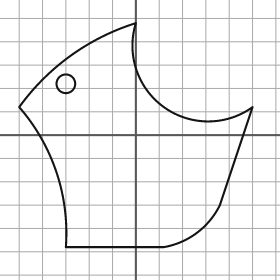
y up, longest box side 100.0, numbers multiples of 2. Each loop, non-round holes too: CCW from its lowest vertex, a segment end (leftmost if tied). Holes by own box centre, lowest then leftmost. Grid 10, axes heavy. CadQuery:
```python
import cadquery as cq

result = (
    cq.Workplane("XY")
    .moveTo(-30.0, -48.0)
    .lineTo(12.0, -48.0)
    .threePointArc((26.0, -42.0), (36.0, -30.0))
    .lineTo(50.0, 12.0)
    .threePointArc((12.0, 12.0), (0.0, 48.0))
    .threePointArc((-28.0, 34.0), (-50.0, 12.0))
    .threePointArc((-34.0, -16.0), (-30.0, -48.0))
    .close()
    .moveTo(-30.0, 22.0)
    .circle(4.0)
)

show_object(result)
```